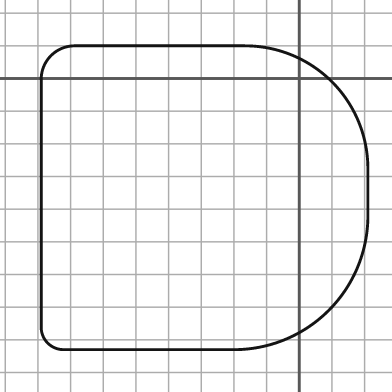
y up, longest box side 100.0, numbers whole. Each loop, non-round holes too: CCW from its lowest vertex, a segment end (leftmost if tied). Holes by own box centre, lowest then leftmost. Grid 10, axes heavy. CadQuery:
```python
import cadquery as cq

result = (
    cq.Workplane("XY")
    .moveTo(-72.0, -83.0)
    .lineTo(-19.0, -83.0)
    .threePointArc((9.0, -71.0), (21.0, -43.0))
    .lineTo(21.0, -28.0)
    .threePointArc((10.0, -1.0), (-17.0, 10.0))
    .lineTo(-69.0, 10.0)
    .threePointArc((-76.0, 7.0), (-79.0, 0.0))
    .lineTo(-79.0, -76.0)
    .threePointArc((-77.0, -81.0), (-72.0, -83.0))
    .close()
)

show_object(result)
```